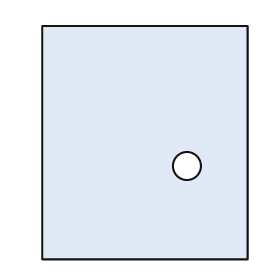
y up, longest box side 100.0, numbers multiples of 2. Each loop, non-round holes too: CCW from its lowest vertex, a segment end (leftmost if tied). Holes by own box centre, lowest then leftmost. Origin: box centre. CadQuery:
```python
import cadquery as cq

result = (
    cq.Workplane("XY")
    .moveTo(-44.0, -50.0)
    .lineTo(44.0, -50.0)
    .lineTo(44.0, 50.0)
    .lineTo(-44.0, 50.0)
    .close()
    .moveTo(18.0, -10.0)
    .circle(6.0)
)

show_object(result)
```